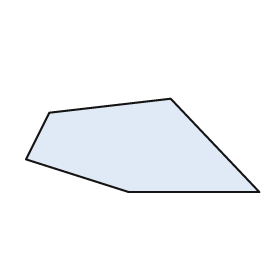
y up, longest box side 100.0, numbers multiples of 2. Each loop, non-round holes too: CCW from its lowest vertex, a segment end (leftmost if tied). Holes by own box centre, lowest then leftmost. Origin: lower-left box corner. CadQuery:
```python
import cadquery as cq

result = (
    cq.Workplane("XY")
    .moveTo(44.0, 0.0)
    .lineTo(100.0, 0.0)
    .lineTo(62.0, 40.0)
    .lineTo(10.0, 34.0)
    .lineTo(0.0, 14.0)
    .close()
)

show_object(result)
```